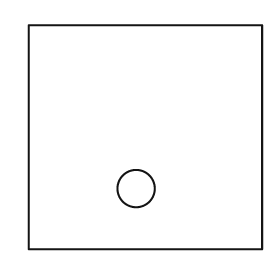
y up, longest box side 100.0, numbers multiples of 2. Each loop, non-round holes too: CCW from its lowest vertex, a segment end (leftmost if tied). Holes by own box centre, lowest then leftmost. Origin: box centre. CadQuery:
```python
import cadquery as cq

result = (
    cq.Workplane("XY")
    .moveTo(-50.0, -48.0)
    .lineTo(50.0, -48.0)
    .lineTo(50.0, 48.0)
    .lineTo(-50.0, 48.0)
    .close()
    .moveTo(-4.0, -22.0)
    .circle(8.0)
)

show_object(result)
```